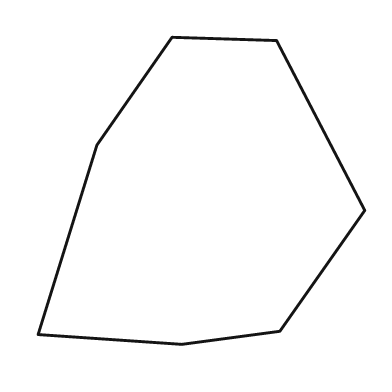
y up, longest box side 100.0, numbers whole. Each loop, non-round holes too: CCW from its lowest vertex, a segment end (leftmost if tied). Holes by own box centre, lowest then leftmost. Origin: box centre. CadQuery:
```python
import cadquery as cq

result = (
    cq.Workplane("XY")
    .moveTo(-6.0, -47.0)
    .lineTo(24.0, -43.0)
    .lineTo(50.0, -6.0)
    .lineTo(23.0, 46.0)
    .lineTo(-9.0, 47.0)
    .lineTo(-32.0, 14.0)
    .lineTo(-50.0, -44.0)
    .close()
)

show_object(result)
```